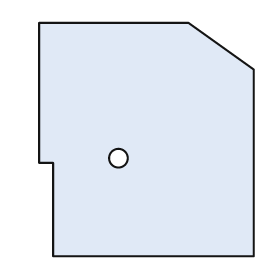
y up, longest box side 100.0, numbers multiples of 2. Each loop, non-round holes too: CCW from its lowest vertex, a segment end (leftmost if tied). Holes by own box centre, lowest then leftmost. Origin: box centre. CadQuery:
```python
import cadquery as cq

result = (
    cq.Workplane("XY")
    .moveTo(-40.0, -50.0)
    .lineTo(46.0, -50.0)
    .lineTo(46.0, 30.0)
    .lineTo(18.0, 50.0)
    .lineTo(-46.0, 50.0)
    .lineTo(-46.0, -10.0)
    .lineTo(-40.0, -10.0)
    .close()
    .moveTo(-12.0, -8.0)
    .circle(4.0)
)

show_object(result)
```